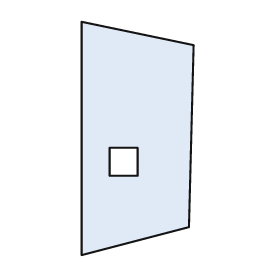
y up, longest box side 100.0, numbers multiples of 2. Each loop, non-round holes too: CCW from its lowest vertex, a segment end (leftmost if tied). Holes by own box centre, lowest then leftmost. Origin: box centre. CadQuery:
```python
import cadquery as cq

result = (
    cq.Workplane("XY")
    .moveTo(-24.0, -50.0)
    .lineTo(22.0, -38.0)
    .lineTo(24.0, 40.0)
    .lineTo(-24.0, 50.0)
    .close()
    .moveTo(-12.0, -16.0)
    .lineTo(0.0, -16.0)
    .lineTo(0.0, -4.0)
    .lineTo(-12.0, -4.0)
    .close()
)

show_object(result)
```